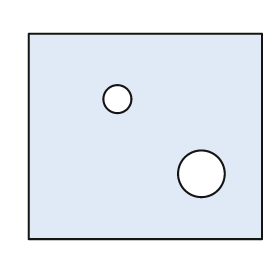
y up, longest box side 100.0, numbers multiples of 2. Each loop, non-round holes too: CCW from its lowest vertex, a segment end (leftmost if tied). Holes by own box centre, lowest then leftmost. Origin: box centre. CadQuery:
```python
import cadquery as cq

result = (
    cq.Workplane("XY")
    .moveTo(-50.0, -44.0)
    .lineTo(50.0, -44.0)
    .lineTo(50.0, 44.0)
    .lineTo(-50.0, 44.0)
    .close()
    .moveTo(24.0, -16.0)
    .circle(10.0)
    .moveTo(-12.0, 16.0)
    .circle(6.0)
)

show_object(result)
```